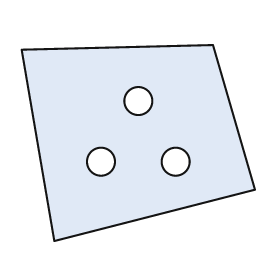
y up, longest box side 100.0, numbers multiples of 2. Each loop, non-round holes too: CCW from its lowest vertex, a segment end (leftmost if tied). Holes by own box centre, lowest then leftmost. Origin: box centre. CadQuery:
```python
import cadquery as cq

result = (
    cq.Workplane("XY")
    .moveTo(-36.0, -42.0)
    .lineTo(50.0, -20.0)
    .lineTo(32.0, 42.0)
    .lineTo(-50.0, 40.0)
    .close()
    .moveTo(-16.0, -8.0)
    .circle(6.0)
    .moveTo(16.0, -8.0)
    .circle(6.0)
    .moveTo(0.0, 18.0)
    .circle(6.0)
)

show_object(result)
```